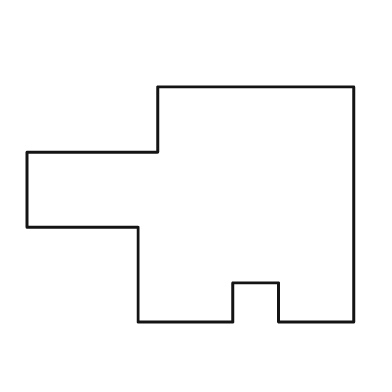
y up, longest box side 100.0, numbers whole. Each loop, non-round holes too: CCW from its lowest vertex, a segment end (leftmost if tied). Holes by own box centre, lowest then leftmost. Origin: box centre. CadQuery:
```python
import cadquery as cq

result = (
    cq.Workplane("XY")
    .moveTo(-16.0, -36.0)
    .lineTo(13.0, -36.0)
    .lineTo(13.0, -24.0)
    .lineTo(27.0, -24.0)
    .lineTo(27.0, -36.0)
    .lineTo(50.0, -36.0)
    .lineTo(50.0, 36.0)
    .lineTo(-10.0, 36.0)
    .lineTo(-10.0, 16.0)
    .lineTo(-50.0, 16.0)
    .lineTo(-50.0, -7.0)
    .lineTo(-16.0, -7.0)
    .close()
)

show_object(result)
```